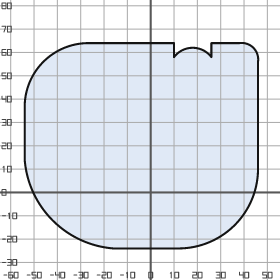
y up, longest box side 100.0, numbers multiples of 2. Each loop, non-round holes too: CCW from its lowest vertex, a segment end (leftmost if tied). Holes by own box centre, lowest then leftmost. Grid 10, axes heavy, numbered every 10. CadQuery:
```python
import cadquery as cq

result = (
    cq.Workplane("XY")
    .moveTo(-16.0, -24.0)
    .lineTo(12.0, -24.0)
    .threePointArc((36.0, -14.0), (46.0, 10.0))
    .lineTo(46.0, 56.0)
    .threePointArc((44.0, 62.0), (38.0, 64.0))
    .lineTo(26.0, 64.0)
    .lineTo(26.0, 58.0)
    .threePointArc((18.0, 62.0), (10.0, 58.0))
    .lineTo(10.0, 64.0)
    .lineTo(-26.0, 64.0)
    .threePointArc((-46.0, 56.0), (-54.0, 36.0))
    .lineTo(-54.0, 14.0)
    .threePointArc((-42.0, -12.0), (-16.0, -24.0))
    .close()
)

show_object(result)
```